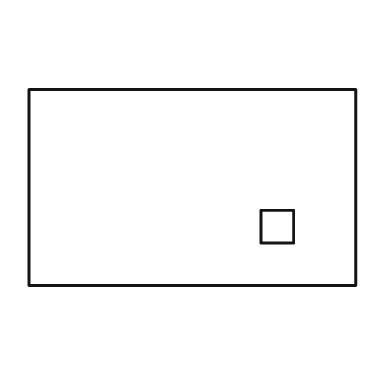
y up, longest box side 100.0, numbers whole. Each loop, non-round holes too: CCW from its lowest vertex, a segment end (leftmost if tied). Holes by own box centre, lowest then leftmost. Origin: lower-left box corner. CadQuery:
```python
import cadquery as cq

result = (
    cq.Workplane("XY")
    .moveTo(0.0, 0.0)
    .lineTo(100.0, 0.0)
    .lineTo(100.0, 60.0)
    .lineTo(0.0, 60.0)
    .close()
    .moveTo(71.0, 13.0)
    .lineTo(81.0, 13.0)
    .lineTo(81.0, 23.0)
    .lineTo(71.0, 23.0)
    .close()
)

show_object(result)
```